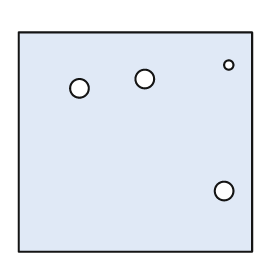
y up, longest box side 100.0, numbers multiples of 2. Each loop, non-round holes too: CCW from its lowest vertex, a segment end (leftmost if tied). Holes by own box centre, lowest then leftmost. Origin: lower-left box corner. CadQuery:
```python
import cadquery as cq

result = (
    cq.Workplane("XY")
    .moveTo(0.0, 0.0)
    .lineTo(100.0, 0.0)
    .lineTo(100.0, 94.0)
    .lineTo(0.0, 94.0)
    .close()
    .moveTo(88.0, 26.0)
    .circle(4.0)
    .moveTo(26.0, 70.0)
    .circle(4.0)
    .moveTo(54.0, 74.0)
    .circle(4.0)
    .moveTo(90.0, 80.0)
    .circle(2.0)
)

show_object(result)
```